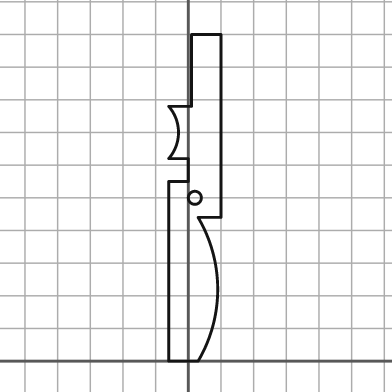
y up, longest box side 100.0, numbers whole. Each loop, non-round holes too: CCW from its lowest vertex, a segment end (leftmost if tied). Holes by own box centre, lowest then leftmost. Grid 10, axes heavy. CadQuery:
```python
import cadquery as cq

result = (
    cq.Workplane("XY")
    .moveTo(-6.0, 0.0)
    .lineTo(3.0, 0.0)
    .threePointArc((9.0, 22.0), (3.0, 44.0))
    .lineTo(10.0, 44.0)
    .lineTo(10.0, 100.0)
    .lineTo(1.0, 100.0)
    .lineTo(1.0, 78.0)
    .lineTo(-6.0, 78.0)
    .threePointArc((-3.0, 70.0), (-6.0, 62.0))
    .lineTo(0.0, 62.0)
    .lineTo(0.0, 55.0)
    .lineTo(-6.0, 55.0)
    .close()
    .moveTo(2.0, 50.0)
    .circle(2.0)
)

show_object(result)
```